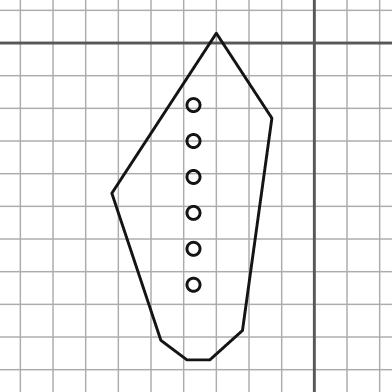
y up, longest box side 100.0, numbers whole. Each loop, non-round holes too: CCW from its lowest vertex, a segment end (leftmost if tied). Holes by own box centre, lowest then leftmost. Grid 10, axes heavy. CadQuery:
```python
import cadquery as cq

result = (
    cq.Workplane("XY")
    .moveTo(-39.0, -97.0)
    .lineTo(-32.0, -97.0)
    .lineTo(-22.0, -88.0)
    .lineTo(-13.0, -23.0)
    .lineTo(-30.0, 3.0)
    .lineTo(-62.0, -46.0)
    .lineTo(-47.0, -91.0)
    .close()
    .moveTo(-37.0, -74.0)
    .circle(2.0)
    .moveTo(-37.0, -63.0)
    .circle(2.0)
    .moveTo(-37.0, -52.0)
    .circle(2.0)
    .moveTo(-37.0, -41.0)
    .circle(2.0)
    .moveTo(-37.0, -30.0)
    .circle(2.0)
    .moveTo(-37.0, -19.0)
    .circle(2.0)
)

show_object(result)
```